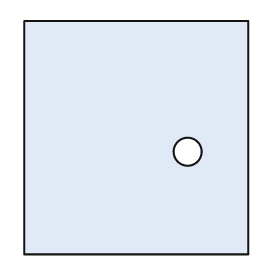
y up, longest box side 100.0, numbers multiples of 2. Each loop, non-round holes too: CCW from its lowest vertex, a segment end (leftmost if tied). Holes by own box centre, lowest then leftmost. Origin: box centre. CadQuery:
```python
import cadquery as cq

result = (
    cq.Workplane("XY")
    .moveTo(-48.0, -50.0)
    .lineTo(48.0, -50.0)
    .lineTo(48.0, 50.0)
    .lineTo(-48.0, 50.0)
    .close()
    .moveTo(22.0, -6.0)
    .circle(6.0)
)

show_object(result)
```